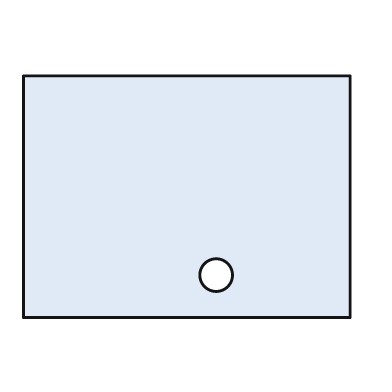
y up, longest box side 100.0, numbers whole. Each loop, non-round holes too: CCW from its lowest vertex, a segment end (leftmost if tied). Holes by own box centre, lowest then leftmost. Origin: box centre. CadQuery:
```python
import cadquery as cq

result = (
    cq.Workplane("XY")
    .moveTo(-50.0, -37.0)
    .lineTo(50.0, -37.0)
    .lineTo(50.0, 37.0)
    .lineTo(-50.0, 37.0)
    .close()
    .moveTo(9.0, -24.0)
    .circle(5.0)
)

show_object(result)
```